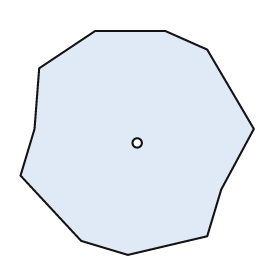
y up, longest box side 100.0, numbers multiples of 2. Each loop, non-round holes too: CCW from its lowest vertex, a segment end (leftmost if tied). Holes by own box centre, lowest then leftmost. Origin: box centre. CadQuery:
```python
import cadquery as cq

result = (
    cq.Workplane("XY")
    .moveTo(-4.0, -48.0)
    .lineTo(30.0, -40.0)
    .lineTo(36.0, -20.0)
    .lineTo(50.0, 6.0)
    .lineTo(30.0, 40.0)
    .lineTo(12.0, 48.0)
    .lineTo(-18.0, 48.0)
    .lineTo(-42.0, 32.0)
    .lineTo(-44.0, 6.0)
    .lineTo(-50.0, -14.0)
    .lineTo(-24.0, -42.0)
    .close()
    .moveTo(0.0, 0.0)
    .circle(2.0)
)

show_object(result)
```